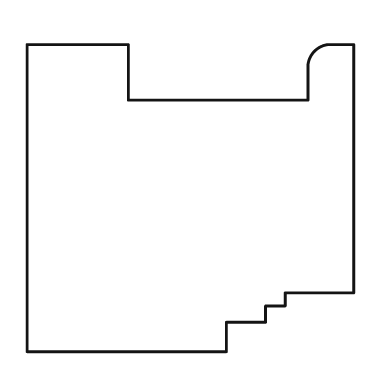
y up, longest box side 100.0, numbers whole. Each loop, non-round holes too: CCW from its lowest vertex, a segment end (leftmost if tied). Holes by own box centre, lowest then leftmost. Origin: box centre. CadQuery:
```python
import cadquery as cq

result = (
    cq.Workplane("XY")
    .moveTo(-50.0, -47.0)
    .lineTo(11.0, -47.0)
    .lineTo(11.0, -38.0)
    .lineTo(23.0, -38.0)
    .lineTo(23.0, -33.0)
    .lineTo(29.0, -33.0)
    .lineTo(29.0, -29.0)
    .lineTo(50.0, -29.0)
    .lineTo(50.0, 47.0)
    .lineTo(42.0, 47.0)
    .threePointArc((38.0, 45.0), (36.0, 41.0))
    .lineTo(36.0, 30.0)
    .lineTo(-19.0, 30.0)
    .lineTo(-19.0, 47.0)
    .lineTo(-50.0, 47.0)
    .close()
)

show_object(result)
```